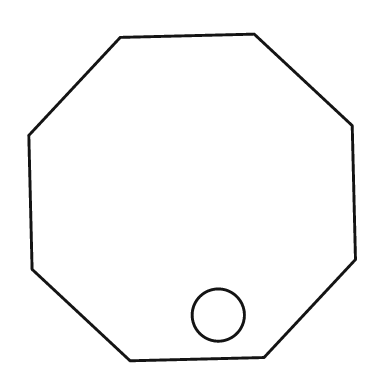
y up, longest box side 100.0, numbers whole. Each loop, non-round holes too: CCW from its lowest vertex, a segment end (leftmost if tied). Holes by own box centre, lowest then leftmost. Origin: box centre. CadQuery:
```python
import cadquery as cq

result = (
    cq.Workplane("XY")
    .moveTo(-19.0, -50.0)
    .lineTo(22.0, -49.0)
    .lineTo(50.0, -19.0)
    .lineTo(49.0, 22.0)
    .lineTo(19.0, 50.0)
    .lineTo(-22.0, 49.0)
    .lineTo(-50.0, 19.0)
    .lineTo(-49.0, -22.0)
    .close()
    .moveTo(8.0, -36.0)
    .circle(8.0)
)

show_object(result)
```